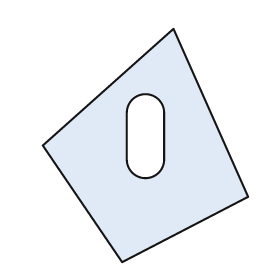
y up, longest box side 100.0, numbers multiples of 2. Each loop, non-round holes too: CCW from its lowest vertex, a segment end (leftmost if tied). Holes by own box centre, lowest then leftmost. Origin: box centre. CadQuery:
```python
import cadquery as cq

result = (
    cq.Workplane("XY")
    .moveTo(-10.0, -50.0)
    .lineTo(44.0, -22.0)
    .lineTo(12.0, 50.0)
    .lineTo(-44.0, 0.0)
    .close()
    .moveTo(-8.0, -6.0)
    .threePointArc((0.0, -14.0), (8.0, -6.0))
    .lineTo(8.0, 14.0)
    .threePointArc((0.0, 22.0), (-8.0, 14.0))
    .close()
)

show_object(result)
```